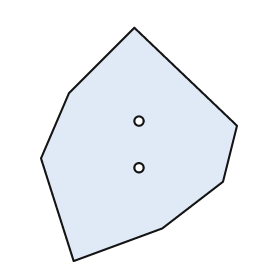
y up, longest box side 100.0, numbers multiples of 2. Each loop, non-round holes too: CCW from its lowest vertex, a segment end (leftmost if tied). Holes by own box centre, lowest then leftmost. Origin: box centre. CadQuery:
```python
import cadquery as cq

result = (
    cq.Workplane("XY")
    .moveTo(-28.0, -50.0)
    .lineTo(10.0, -36.0)
    .lineTo(36.0, -16.0)
    .lineTo(42.0, 8.0)
    .lineTo(-2.0, 50.0)
    .lineTo(-30.0, 22.0)
    .lineTo(-42.0, -6.0)
    .close()
    .moveTo(0.0, -10.0)
    .circle(2.0)
    .moveTo(0.0, 10.0)
    .circle(2.0)
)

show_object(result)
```